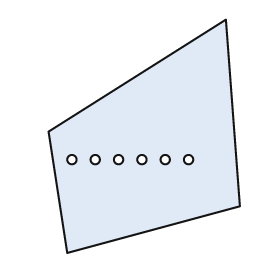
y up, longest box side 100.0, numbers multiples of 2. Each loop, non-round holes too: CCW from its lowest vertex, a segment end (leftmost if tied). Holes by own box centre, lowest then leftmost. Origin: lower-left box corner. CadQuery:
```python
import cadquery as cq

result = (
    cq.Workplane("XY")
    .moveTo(8.0, 0.0)
    .lineTo(82.0, 20.0)
    .lineTo(76.0, 100.0)
    .lineTo(0.0, 52.0)
    .close()
    .moveTo(10.0, 40.0)
    .circle(2.0)
    .moveTo(20.0, 40.0)
    .circle(2.0)
    .moveTo(30.0, 40.0)
    .circle(2.0)
    .moveTo(40.0, 40.0)
    .circle(2.0)
    .moveTo(50.0, 40.0)
    .circle(2.0)
    .moveTo(60.0, 40.0)
    .circle(2.0)
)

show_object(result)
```